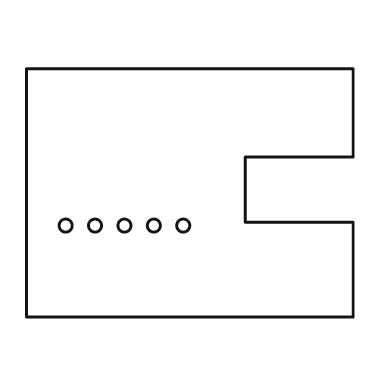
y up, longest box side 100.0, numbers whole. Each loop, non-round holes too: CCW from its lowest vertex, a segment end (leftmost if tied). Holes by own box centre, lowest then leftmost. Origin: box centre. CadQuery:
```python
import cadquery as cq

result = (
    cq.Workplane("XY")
    .moveTo(-50.0, -38.0)
    .lineTo(50.0, -38.0)
    .lineTo(50.0, -9.0)
    .lineTo(17.0, -9.0)
    .lineTo(17.0, 11.0)
    .lineTo(50.0, 11.0)
    .lineTo(50.0, 38.0)
    .lineTo(-50.0, 38.0)
    .close()
    .moveTo(-38.0, -10.0)
    .circle(2.0)
    .moveTo(-29.0, -10.0)
    .circle(2.0)
    .moveTo(-20.0, -10.0)
    .circle(2.0)
    .moveTo(-11.0, -10.0)
    .circle(2.0)
    .moveTo(-2.0, -10.0)
    .circle(2.0)
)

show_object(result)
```